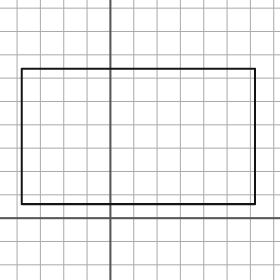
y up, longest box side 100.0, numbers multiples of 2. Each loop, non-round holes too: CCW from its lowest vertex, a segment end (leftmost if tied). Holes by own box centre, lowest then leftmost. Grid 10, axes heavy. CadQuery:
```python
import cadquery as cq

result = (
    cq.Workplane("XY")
    .moveTo(-38.0, 6.0)
    .lineTo(62.0, 6.0)
    .lineTo(62.0, 64.0)
    .lineTo(-38.0, 64.0)
    .close()
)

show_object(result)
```